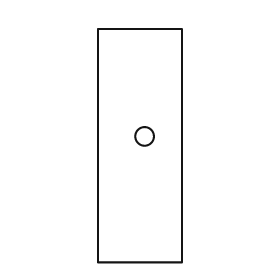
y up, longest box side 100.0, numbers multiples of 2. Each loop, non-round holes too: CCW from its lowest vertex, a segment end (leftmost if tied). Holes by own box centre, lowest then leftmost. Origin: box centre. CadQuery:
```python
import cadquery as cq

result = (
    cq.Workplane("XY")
    .moveTo(-18.0, -50.0)
    .lineTo(18.0, -50.0)
    .lineTo(18.0, 50.0)
    .lineTo(-18.0, 50.0)
    .close()
    .moveTo(2.0, 4.0)
    .circle(4.0)
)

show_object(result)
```